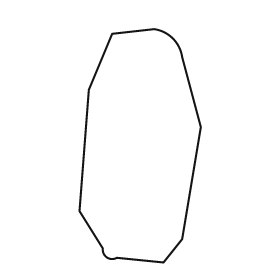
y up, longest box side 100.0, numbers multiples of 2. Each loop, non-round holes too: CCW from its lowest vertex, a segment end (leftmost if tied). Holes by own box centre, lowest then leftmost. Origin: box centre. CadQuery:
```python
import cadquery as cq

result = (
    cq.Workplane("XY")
    .moveTo(10.0, -50.0)
    .lineTo(18.0, -40.0)
    .lineTo(26.0, 8.0)
    .lineTo(18.0, 38.0)
    .threePointArc((14.0, 46.0), (6.0, 50.0))
    .lineTo(-12.0, 48.0)
    .lineTo(-22.0, 24.0)
    .lineTo(-26.0, -28.0)
    .lineTo(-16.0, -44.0)
    .threePointArc((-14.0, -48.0), (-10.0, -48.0))
    .close()
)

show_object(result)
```